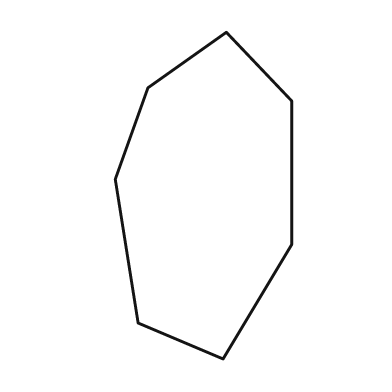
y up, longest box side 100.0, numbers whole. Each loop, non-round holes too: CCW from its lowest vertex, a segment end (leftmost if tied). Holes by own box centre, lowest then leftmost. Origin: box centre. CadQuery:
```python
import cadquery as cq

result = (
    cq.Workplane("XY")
    .moveTo(6.0, -50.0)
    .lineTo(27.0, -15.0)
    .lineTo(27.0, 29.0)
    .lineTo(7.0, 50.0)
    .lineTo(-17.0, 33.0)
    .lineTo(-27.0, 5.0)
    .lineTo(-20.0, -39.0)
    .close()
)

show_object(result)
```